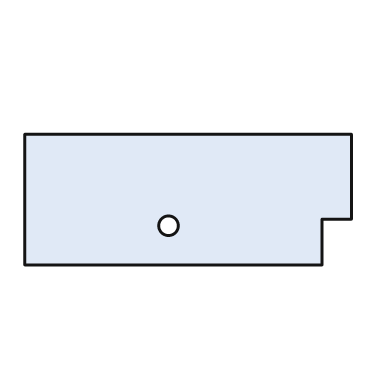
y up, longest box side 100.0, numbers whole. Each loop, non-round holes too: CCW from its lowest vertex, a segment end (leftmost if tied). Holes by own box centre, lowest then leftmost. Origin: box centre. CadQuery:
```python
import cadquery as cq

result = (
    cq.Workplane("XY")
    .moveTo(-50.0, -20.0)
    .lineTo(41.0, -20.0)
    .lineTo(41.0, -6.0)
    .lineTo(50.0, -6.0)
    .lineTo(50.0, 20.0)
    .lineTo(-50.0, 20.0)
    .close()
    .moveTo(-6.0, -8.0)
    .circle(3.0)
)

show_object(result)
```